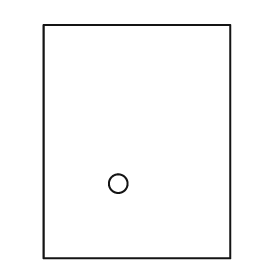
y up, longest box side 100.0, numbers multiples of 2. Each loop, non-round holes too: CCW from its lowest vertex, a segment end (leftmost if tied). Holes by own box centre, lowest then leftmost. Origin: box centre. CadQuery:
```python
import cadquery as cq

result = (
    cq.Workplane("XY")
    .moveTo(-40.0, -50.0)
    .lineTo(40.0, -50.0)
    .lineTo(40.0, 50.0)
    .lineTo(-40.0, 50.0)
    .close()
    .moveTo(-8.0, -18.0)
    .circle(4.0)
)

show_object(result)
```